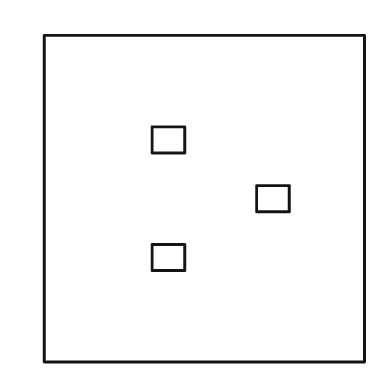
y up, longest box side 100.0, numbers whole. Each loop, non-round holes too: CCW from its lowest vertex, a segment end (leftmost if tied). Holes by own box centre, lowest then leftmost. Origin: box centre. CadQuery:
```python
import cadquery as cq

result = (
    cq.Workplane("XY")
    .moveTo(-49.0, -50.0)
    .lineTo(49.0, -50.0)
    .lineTo(49.0, 50.0)
    .lineTo(-49.0, 50.0)
    .close()
    .moveTo(-16.0, -22.0)
    .lineTo(-6.0, -22.0)
    .lineTo(-6.0, -14.0)
    .lineTo(-16.0, -14.0)
    .close()
    .moveTo(16.0, -4.0)
    .lineTo(26.0, -4.0)
    .lineTo(26.0, 4.0)
    .lineTo(16.0, 4.0)
    .close()
    .moveTo(-16.0, 14.0)
    .lineTo(-6.0, 14.0)
    .lineTo(-6.0, 22.0)
    .lineTo(-16.0, 22.0)
    .close()
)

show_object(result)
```